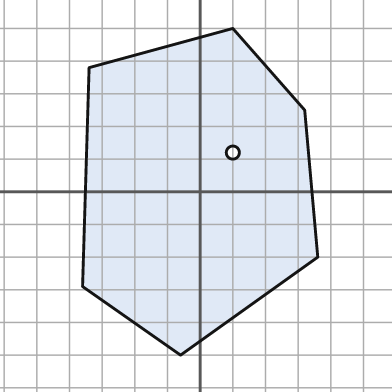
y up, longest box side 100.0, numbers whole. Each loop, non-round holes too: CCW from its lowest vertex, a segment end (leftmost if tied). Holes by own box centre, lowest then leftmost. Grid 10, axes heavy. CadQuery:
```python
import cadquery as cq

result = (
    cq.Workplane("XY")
    .moveTo(-6.0, -50.0)
    .lineTo(36.0, -20.0)
    .lineTo(32.0, 25.0)
    .lineTo(10.0, 50.0)
    .lineTo(-34.0, 38.0)
    .lineTo(-36.0, -29.0)
    .close()
    .moveTo(10.0, 12.0)
    .circle(2.0)
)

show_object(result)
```